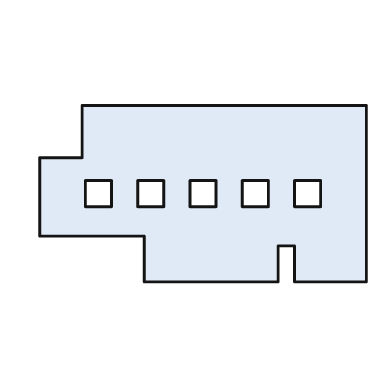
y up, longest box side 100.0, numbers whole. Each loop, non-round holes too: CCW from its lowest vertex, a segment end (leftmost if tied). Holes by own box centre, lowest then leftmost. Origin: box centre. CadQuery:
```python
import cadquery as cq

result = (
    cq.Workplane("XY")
    .moveTo(-18.0, -27.0)
    .lineTo(23.0, -27.0)
    .lineTo(23.0, -16.0)
    .lineTo(28.0, -16.0)
    .lineTo(28.0, -27.0)
    .lineTo(50.0, -27.0)
    .lineTo(50.0, 27.0)
    .lineTo(-37.0, 27.0)
    .lineTo(-37.0, 11.0)
    .lineTo(-50.0, 11.0)
    .lineTo(-50.0, -13.0)
    .lineTo(-18.0, -13.0)
    .close()
    .moveTo(-36.0, -4.0)
    .lineTo(-28.0, -4.0)
    .lineTo(-28.0, 4.0)
    .lineTo(-36.0, 4.0)
    .close()
    .moveTo(-20.0, -4.0)
    .lineTo(-12.0, -4.0)
    .lineTo(-12.0, 4.0)
    .lineTo(-20.0, 4.0)
    .close()
    .moveTo(-4.0, -4.0)
    .lineTo(4.0, -4.0)
    .lineTo(4.0, 4.0)
    .lineTo(-4.0, 4.0)
    .close()
    .moveTo(12.0, -4.0)
    .lineTo(20.0, -4.0)
    .lineTo(20.0, 4.0)
    .lineTo(12.0, 4.0)
    .close()
    .moveTo(28.0, -4.0)
    .lineTo(36.0, -4.0)
    .lineTo(36.0, 4.0)
    .lineTo(28.0, 4.0)
    .close()
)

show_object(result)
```